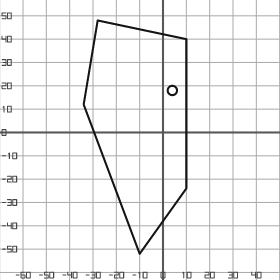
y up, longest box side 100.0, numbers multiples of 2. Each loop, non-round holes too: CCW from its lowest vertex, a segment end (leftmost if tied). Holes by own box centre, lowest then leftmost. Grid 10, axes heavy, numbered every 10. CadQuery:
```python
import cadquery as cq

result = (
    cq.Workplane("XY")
    .moveTo(-10.0, -52.0)
    .lineTo(10.0, -24.0)
    .lineTo(10.0, 40.0)
    .lineTo(-28.0, 48.0)
    .lineTo(-34.0, 12.0)
    .close()
    .moveTo(4.0, 18.0)
    .circle(2.0)
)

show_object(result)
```